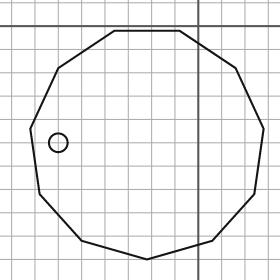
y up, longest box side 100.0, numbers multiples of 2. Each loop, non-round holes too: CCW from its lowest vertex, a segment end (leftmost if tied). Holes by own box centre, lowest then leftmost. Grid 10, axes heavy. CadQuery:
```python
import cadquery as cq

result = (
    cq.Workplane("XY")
    .moveTo(-22.0, -100.0)
    .lineTo(6.0, -92.0)
    .lineTo(24.0, -72.0)
    .lineTo(28.0, -44.0)
    .lineTo(16.0, -18.0)
    .lineTo(-8.0, -2.0)
    .lineTo(-36.0, -2.0)
    .lineTo(-60.0, -18.0)
    .lineTo(-72.0, -44.0)
    .lineTo(-68.0, -72.0)
    .lineTo(-50.0, -92.0)
    .close()
    .moveTo(-60.0, -50.0)
    .circle(4.0)
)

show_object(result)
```